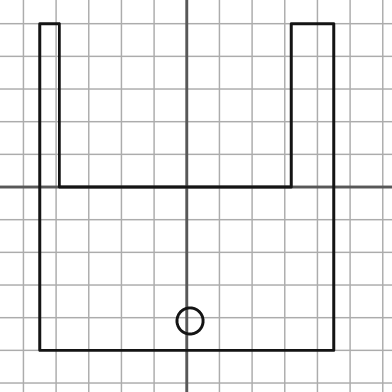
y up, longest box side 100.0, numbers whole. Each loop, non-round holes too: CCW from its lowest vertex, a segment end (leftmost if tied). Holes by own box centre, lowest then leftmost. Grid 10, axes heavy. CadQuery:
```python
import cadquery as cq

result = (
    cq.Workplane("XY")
    .moveTo(-45.0, -50.0)
    .lineTo(45.0, -50.0)
    .lineTo(45.0, 50.0)
    .lineTo(32.0, 50.0)
    .lineTo(32.0, 0.0)
    .lineTo(-39.0, 0.0)
    .lineTo(-39.0, 50.0)
    .lineTo(-45.0, 50.0)
    .close()
    .moveTo(1.0, -41.0)
    .circle(4.0)
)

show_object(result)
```